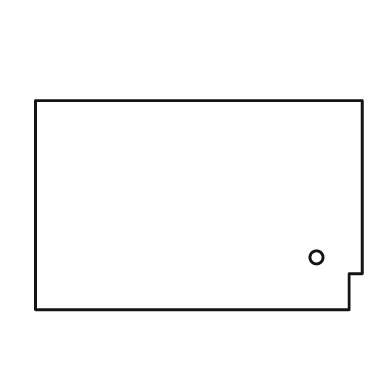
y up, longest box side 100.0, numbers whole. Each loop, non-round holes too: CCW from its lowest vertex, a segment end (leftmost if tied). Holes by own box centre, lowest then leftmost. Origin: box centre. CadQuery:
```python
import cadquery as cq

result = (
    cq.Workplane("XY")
    .moveTo(-50.0, -32.0)
    .lineTo(46.0, -32.0)
    .lineTo(46.0, -21.0)
    .lineTo(50.0, -21.0)
    .lineTo(50.0, 32.0)
    .lineTo(-50.0, 32.0)
    .close()
    .moveTo(36.0, -16.0)
    .circle(2.0)
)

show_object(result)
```